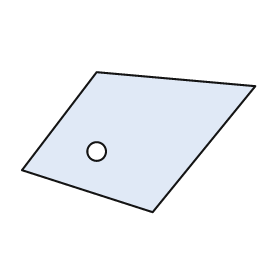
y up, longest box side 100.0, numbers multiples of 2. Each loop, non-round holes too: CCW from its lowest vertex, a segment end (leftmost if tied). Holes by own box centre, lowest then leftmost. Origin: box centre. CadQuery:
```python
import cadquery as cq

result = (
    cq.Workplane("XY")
    .moveTo(6.0, -30.0)
    .lineTo(50.0, 24.0)
    .lineTo(-18.0, 30.0)
    .lineTo(-50.0, -12.0)
    .close()
    .moveTo(-18.0, -4.0)
    .circle(4.0)
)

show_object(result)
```